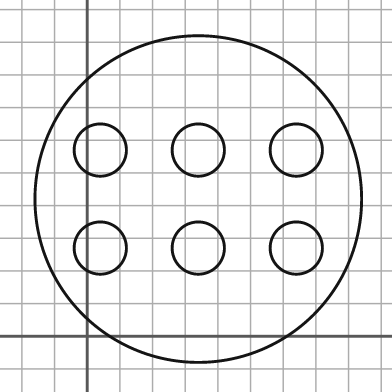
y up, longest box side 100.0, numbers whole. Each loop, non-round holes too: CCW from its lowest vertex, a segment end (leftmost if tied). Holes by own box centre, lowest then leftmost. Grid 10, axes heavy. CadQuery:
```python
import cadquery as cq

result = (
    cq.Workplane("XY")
    .moveTo(34.0, 42.0)
    .circle(50.0)
    .moveTo(4.0, 27.0)
    .circle(8.0)
    .moveTo(34.0, 27.0)
    .circle(8.0)
    .moveTo(64.0, 27.0)
    .circle(8.0)
    .moveTo(4.0, 57.0)
    .circle(8.0)
    .moveTo(34.0, 57.0)
    .circle(8.0)
    .moveTo(64.0, 57.0)
    .circle(8.0)
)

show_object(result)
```